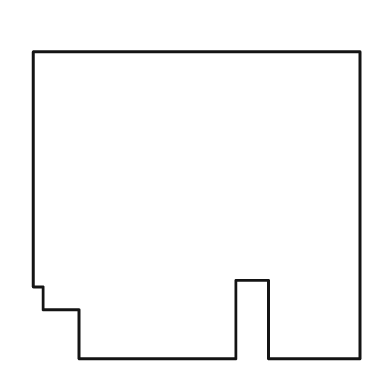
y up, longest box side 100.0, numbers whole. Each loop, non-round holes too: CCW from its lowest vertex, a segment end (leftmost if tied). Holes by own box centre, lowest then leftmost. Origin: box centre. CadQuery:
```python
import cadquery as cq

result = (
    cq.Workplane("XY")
    .moveTo(-36.0, -47.0)
    .lineTo(12.0, -47.0)
    .lineTo(12.0, -23.0)
    .lineTo(22.0, -23.0)
    .lineTo(22.0, -47.0)
    .lineTo(50.0, -47.0)
    .lineTo(50.0, 47.0)
    .lineTo(-50.0, 47.0)
    .lineTo(-50.0, -25.0)
    .lineTo(-47.0, -25.0)
    .lineTo(-47.0, -32.0)
    .lineTo(-36.0, -32.0)
    .close()
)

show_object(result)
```